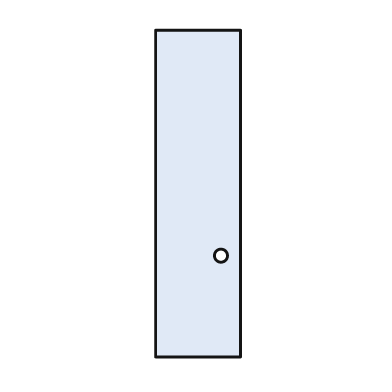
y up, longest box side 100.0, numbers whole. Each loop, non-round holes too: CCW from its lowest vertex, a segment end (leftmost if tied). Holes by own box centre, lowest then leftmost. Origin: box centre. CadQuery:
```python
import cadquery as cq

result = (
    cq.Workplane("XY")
    .moveTo(-13.0, -50.0)
    .lineTo(13.0, -50.0)
    .lineTo(13.0, 50.0)
    .lineTo(-13.0, 50.0)
    .close()
    .moveTo(7.0, -19.0)
    .circle(2.0)
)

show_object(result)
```